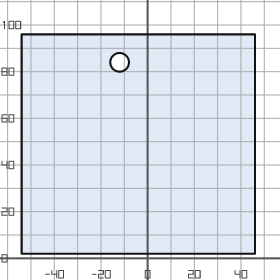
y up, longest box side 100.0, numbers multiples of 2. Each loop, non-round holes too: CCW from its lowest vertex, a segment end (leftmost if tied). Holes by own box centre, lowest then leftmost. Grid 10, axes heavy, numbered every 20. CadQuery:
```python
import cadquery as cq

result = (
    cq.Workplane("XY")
    .moveTo(-54.0, 2.0)
    .lineTo(46.0, 2.0)
    .lineTo(46.0, 96.0)
    .lineTo(-54.0, 96.0)
    .close()
    .moveTo(-12.0, 84.0)
    .circle(4.0)
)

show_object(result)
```